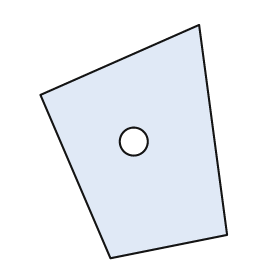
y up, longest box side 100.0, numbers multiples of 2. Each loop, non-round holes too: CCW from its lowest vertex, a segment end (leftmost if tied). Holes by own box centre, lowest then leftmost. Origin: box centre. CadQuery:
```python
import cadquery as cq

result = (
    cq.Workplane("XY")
    .moveTo(-10.0, -50.0)
    .lineTo(40.0, -40.0)
    .lineTo(28.0, 50.0)
    .lineTo(-40.0, 20.0)
    .close()
    .moveTo(0.0, 0.0)
    .circle(6.0)
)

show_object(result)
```